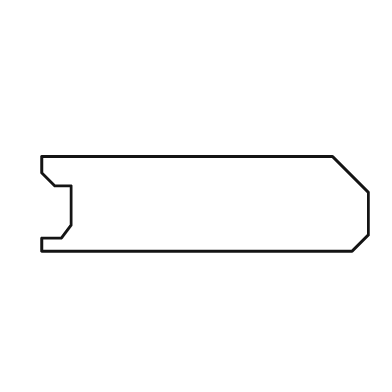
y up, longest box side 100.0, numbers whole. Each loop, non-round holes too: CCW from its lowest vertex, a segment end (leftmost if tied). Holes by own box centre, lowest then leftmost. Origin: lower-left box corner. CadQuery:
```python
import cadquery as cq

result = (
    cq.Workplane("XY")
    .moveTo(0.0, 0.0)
    .lineTo(95.0, 0.0)
    .lineTo(100.0, 5.0)
    .lineTo(100.0, 18.0)
    .lineTo(89.0, 29.0)
    .lineTo(0.0, 29.0)
    .lineTo(0.0, 24.0)
    .lineTo(4.0, 20.0)
    .lineTo(9.0, 20.0)
    .lineTo(9.0, 8.0)
    .lineTo(6.0, 4.0)
    .lineTo(0.0, 4.0)
    .close()
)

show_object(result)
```